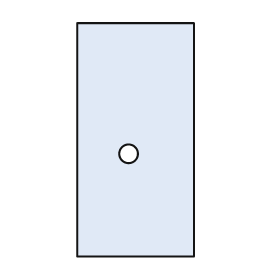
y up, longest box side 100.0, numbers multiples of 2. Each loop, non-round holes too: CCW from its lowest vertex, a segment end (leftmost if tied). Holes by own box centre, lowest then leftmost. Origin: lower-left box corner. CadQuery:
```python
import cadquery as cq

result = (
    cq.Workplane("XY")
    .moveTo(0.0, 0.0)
    .lineTo(50.0, 0.0)
    .lineTo(50.0, 100.0)
    .lineTo(0.0, 100.0)
    .close()
    .moveTo(22.0, 44.0)
    .circle(4.0)
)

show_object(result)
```